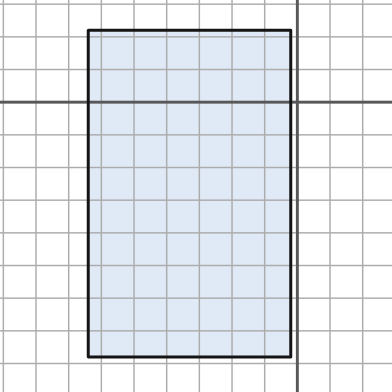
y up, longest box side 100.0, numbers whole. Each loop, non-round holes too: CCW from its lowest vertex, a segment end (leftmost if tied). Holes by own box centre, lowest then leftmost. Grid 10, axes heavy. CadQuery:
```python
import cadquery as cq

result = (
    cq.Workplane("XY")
    .moveTo(-64.0, -78.0)
    .lineTo(-2.0, -78.0)
    .lineTo(-2.0, 22.0)
    .lineTo(-64.0, 22.0)
    .close()
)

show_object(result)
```